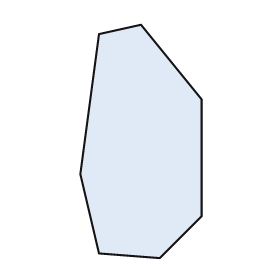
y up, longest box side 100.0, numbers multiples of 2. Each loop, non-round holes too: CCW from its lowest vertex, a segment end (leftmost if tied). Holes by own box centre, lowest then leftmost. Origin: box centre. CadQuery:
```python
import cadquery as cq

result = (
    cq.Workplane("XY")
    .moveTo(8.0, -50.0)
    .lineTo(26.0, -32.0)
    .lineTo(26.0, 18.0)
    .lineTo(0.0, 50.0)
    .lineTo(-18.0, 46.0)
    .lineTo(-26.0, -14.0)
    .lineTo(-18.0, -48.0)
    .close()
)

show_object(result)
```